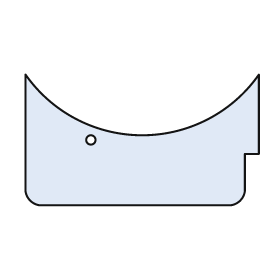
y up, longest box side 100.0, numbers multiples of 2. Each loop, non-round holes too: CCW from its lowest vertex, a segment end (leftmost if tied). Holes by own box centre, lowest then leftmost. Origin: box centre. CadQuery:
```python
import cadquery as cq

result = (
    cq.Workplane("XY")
    .moveTo(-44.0, -28.0)
    .lineTo(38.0, -28.0)
    .threePointArc((42.0, -26.0), (44.0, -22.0))
    .lineTo(44.0, -6.0)
    .lineTo(50.0, -6.0)
    .lineTo(50.0, 28.0)
    .threePointArc((0.0, 2.0), (-50.0, 28.0))
    .lineTo(-50.0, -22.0)
    .threePointArc((-48.0, -26.0), (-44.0, -28.0))
    .close()
    .moveTo(-22.0, 0.0)
    .circle(2.0)
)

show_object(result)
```